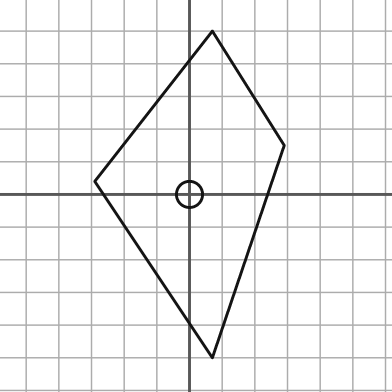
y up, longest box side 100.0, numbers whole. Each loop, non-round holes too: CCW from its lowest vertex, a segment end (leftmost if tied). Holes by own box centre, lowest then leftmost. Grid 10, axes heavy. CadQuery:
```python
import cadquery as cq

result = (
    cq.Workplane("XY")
    .moveTo(7.0, -50.0)
    .lineTo(29.0, 15.0)
    .lineTo(7.0, 50.0)
    .lineTo(-29.0, 4.0)
    .close()
    .moveTo(0.0, 0.0)
    .circle(4.0)
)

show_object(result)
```